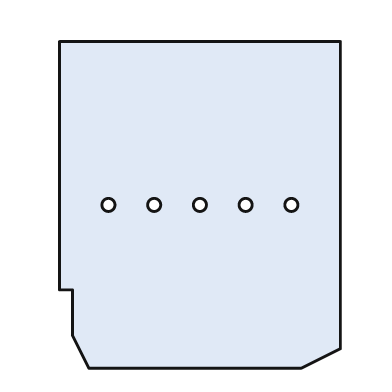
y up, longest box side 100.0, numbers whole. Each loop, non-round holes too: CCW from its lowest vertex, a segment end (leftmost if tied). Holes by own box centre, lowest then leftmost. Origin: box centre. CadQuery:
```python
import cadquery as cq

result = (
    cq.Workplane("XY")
    .moveTo(-34.0, -50.0)
    .lineTo(31.0, -50.0)
    .lineTo(43.0, -44.0)
    .lineTo(43.0, 50.0)
    .lineTo(-43.0, 50.0)
    .lineTo(-43.0, -26.0)
    .lineTo(-39.0, -26.0)
    .lineTo(-39.0, -40.0)
    .close()
    .moveTo(-28.0, 0.0)
    .circle(2.0)
    .moveTo(-14.0, 0.0)
    .circle(2.0)
    .moveTo(0.0, 0.0)
    .circle(2.0)
    .moveTo(14.0, 0.0)
    .circle(2.0)
    .moveTo(28.0, 0.0)
    .circle(2.0)
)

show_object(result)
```